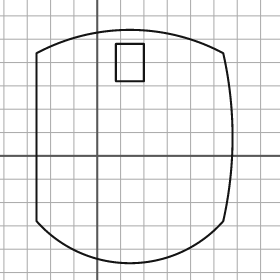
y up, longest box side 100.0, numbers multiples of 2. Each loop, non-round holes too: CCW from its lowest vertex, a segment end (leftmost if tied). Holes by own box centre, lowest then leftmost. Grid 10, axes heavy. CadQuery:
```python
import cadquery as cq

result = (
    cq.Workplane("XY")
    .moveTo(-26.0, -28.0)
    .threePointArc((14.0, -46.0), (54.0, -28.0))
    .threePointArc((58.0, 8.0), (54.0, 44.0))
    .threePointArc((14.0, 54.0), (-26.0, 44.0))
    .close()
    .moveTo(8.0, 32.0)
    .lineTo(20.0, 32.0)
    .lineTo(20.0, 48.0)
    .lineTo(8.0, 48.0)
    .close()
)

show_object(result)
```